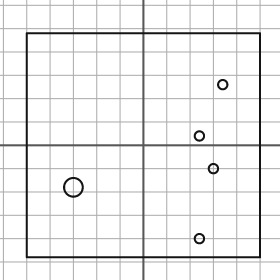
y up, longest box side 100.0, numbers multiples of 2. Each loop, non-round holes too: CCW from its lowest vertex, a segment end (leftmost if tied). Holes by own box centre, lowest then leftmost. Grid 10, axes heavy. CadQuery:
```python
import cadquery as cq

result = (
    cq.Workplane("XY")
    .moveTo(-50.0, -48.0)
    .lineTo(50.0, -48.0)
    .lineTo(50.0, 48.0)
    .lineTo(-50.0, 48.0)
    .close()
    .moveTo(24.0, -40.0)
    .circle(2.0)
    .moveTo(-30.0, -18.0)
    .circle(4.0)
    .moveTo(30.0, -10.0)
    .circle(2.0)
    .moveTo(24.0, 4.0)
    .circle(2.0)
    .moveTo(34.0, 26.0)
    .circle(2.0)
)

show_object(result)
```